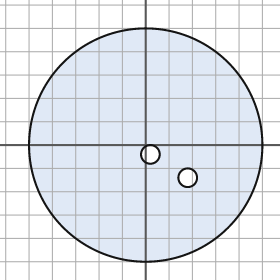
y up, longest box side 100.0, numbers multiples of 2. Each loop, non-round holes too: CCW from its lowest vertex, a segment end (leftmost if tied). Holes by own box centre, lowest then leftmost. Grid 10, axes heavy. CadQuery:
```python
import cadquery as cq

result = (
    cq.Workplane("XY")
    .moveTo(0.0, 0.0)
    .circle(50.0)
    .moveTo(18.0, -14.0)
    .circle(4.0)
    .moveTo(2.0, -4.0)
    .circle(4.0)
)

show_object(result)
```